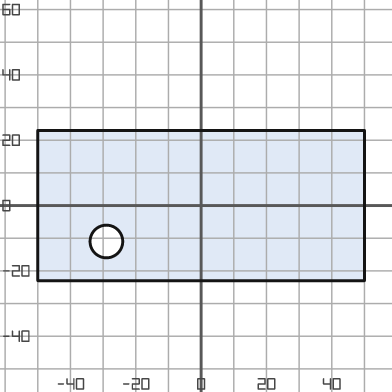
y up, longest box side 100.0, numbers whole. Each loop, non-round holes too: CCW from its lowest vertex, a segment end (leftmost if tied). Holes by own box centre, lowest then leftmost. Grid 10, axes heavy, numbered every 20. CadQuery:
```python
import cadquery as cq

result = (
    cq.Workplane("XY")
    .moveTo(-50.0, -23.0)
    .lineTo(50.0, -23.0)
    .lineTo(50.0, 23.0)
    .lineTo(-50.0, 23.0)
    .close()
    .moveTo(-29.0, -11.0)
    .circle(5.0)
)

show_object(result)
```